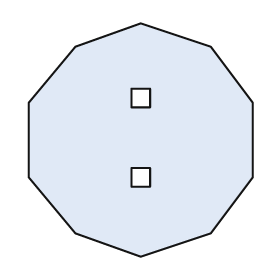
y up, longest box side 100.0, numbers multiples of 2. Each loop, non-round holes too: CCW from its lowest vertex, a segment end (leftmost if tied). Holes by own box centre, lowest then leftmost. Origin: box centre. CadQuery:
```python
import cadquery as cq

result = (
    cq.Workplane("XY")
    .moveTo(0.0, -50.0)
    .lineTo(30.0, -40.0)
    .lineTo(48.0, -16.0)
    .lineTo(48.0, 16.0)
    .lineTo(30.0, 40.0)
    .lineTo(0.0, 50.0)
    .lineTo(-28.0, 40.0)
    .lineTo(-48.0, 16.0)
    .lineTo(-48.0, -16.0)
    .lineTo(-28.0, -40.0)
    .close()
    .moveTo(-4.0, -20.0)
    .lineTo(4.0, -20.0)
    .lineTo(4.0, -12.0)
    .lineTo(-4.0, -12.0)
    .close()
    .moveTo(-4.0, 14.0)
    .lineTo(4.0, 14.0)
    .lineTo(4.0, 22.0)
    .lineTo(-4.0, 22.0)
    .close()
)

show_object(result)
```